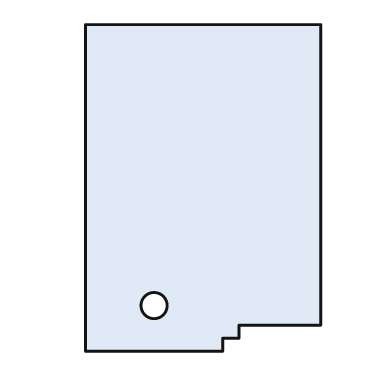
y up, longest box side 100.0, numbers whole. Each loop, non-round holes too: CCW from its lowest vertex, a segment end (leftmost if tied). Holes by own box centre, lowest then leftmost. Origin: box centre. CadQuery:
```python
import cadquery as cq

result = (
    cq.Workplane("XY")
    .moveTo(-36.0, -50.0)
    .lineTo(6.0, -50.0)
    .lineTo(6.0, -46.0)
    .lineTo(11.0, -46.0)
    .lineTo(11.0, -42.0)
    .lineTo(36.0, -42.0)
    .lineTo(36.0, 50.0)
    .lineTo(-36.0, 50.0)
    .close()
    .moveTo(-15.0, -36.0)
    .circle(4.0)
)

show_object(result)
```